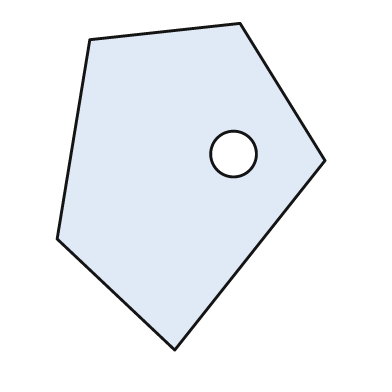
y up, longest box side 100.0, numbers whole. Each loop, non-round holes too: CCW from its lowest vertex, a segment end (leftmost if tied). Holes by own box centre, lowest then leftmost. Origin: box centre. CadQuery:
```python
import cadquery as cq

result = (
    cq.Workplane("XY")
    .moveTo(-5.0, -50.0)
    .lineTo(41.0, 8.0)
    .lineTo(15.0, 50.0)
    .lineTo(-31.0, 45.0)
    .lineTo(-41.0, -16.0)
    .close()
    .moveTo(13.0, 10.0)
    .circle(7.0)
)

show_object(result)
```